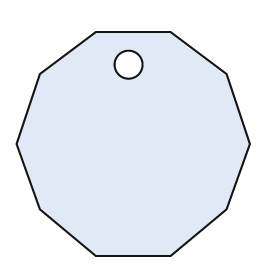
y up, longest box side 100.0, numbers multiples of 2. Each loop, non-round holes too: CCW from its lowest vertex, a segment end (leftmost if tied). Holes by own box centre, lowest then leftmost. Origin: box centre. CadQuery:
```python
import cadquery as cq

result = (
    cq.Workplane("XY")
    .moveTo(-16.0, -48.0)
    .lineTo(16.0, -48.0)
    .lineTo(40.0, -28.0)
    .lineTo(50.0, 0.0)
    .lineTo(40.0, 30.0)
    .lineTo(16.0, 48.0)
    .lineTo(-16.0, 48.0)
    .lineTo(-40.0, 30.0)
    .lineTo(-50.0, 0.0)
    .lineTo(-40.0, -28.0)
    .close()
    .moveTo(-2.0, 34.0)
    .circle(6.0)
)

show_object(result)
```